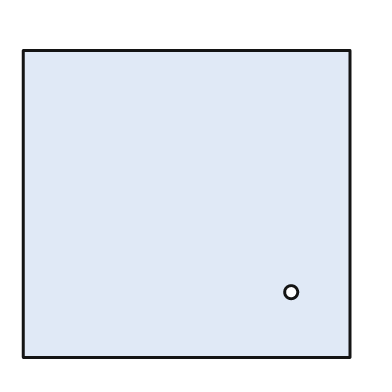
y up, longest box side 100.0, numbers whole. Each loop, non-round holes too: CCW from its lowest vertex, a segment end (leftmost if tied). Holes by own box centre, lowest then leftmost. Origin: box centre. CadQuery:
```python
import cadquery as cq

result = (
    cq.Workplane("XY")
    .moveTo(-50.0, -47.0)
    .lineTo(50.0, -47.0)
    .lineTo(50.0, 47.0)
    .lineTo(-50.0, 47.0)
    .close()
    .moveTo(32.0, -27.0)
    .circle(2.0)
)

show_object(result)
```